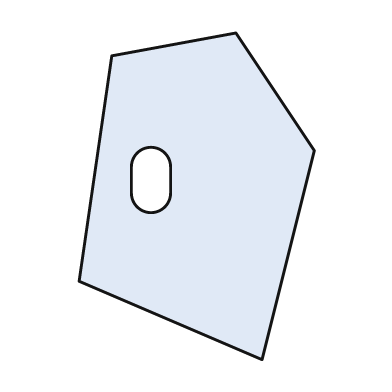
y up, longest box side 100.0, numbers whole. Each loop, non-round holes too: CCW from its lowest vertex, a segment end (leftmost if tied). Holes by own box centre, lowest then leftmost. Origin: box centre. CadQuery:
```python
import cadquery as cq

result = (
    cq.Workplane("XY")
    .moveTo(20.0, -50.0)
    .lineTo(36.0, 14.0)
    .lineTo(12.0, 50.0)
    .lineTo(-26.0, 43.0)
    .lineTo(-36.0, -26.0)
    .close()
    .moveTo(-20.0, 1.0)
    .threePointArc((-14.0, -5.0), (-8.0, 1.0))
    .lineTo(-8.0, 9.0)
    .threePointArc((-14.0, 15.0), (-20.0, 9.0))
    .close()
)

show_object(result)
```